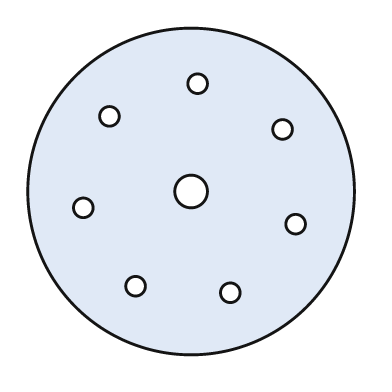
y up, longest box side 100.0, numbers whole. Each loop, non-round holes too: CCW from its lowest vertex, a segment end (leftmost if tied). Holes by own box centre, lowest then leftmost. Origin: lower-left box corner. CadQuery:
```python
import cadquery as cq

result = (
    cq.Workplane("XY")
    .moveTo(50.0, 50.0)
    .circle(50.0)
    .moveTo(62.0, 19.0)
    .circle(3.0)
    .moveTo(33.0, 21.0)
    .circle(3.0)
    .moveTo(82.0, 40.0)
    .circle(3.0)
    .moveTo(17.0, 45.0)
    .circle(3.0)
    .moveTo(50.0, 50.0)
    .circle(5.0)
    .moveTo(78.0, 69.0)
    .circle(3.0)
    .moveTo(25.0, 73.0)
    .circle(3.0)
    .moveTo(52.0, 83.0)
    .circle(3.0)
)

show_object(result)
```